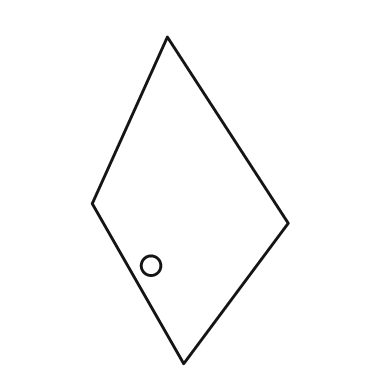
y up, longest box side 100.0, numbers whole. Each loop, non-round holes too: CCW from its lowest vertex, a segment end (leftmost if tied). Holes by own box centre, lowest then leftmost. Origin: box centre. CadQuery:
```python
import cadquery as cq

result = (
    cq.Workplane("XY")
    .moveTo(-2.0, -50.0)
    .lineTo(30.0, -7.0)
    .lineTo(-7.0, 50.0)
    .lineTo(-30.0, -1.0)
    .close()
    .moveTo(-12.0, -20.0)
    .circle(3.0)
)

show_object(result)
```